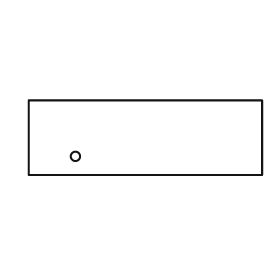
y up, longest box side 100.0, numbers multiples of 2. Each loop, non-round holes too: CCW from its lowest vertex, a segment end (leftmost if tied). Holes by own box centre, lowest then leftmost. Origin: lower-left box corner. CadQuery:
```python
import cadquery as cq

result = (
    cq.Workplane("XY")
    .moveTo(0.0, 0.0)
    .lineTo(100.0, 0.0)
    .lineTo(100.0, 32.0)
    .lineTo(0.0, 32.0)
    .close()
    .moveTo(20.0, 8.0)
    .circle(2.0)
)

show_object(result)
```